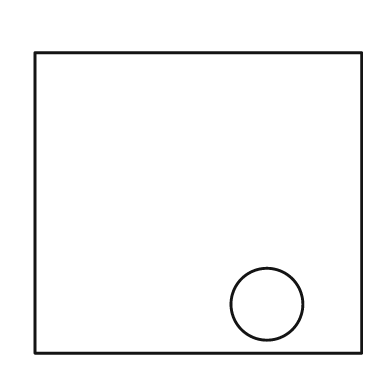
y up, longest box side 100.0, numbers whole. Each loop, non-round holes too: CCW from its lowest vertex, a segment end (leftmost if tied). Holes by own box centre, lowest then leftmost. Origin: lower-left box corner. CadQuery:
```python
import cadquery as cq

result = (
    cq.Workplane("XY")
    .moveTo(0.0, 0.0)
    .lineTo(100.0, 0.0)
    .lineTo(100.0, 92.0)
    .lineTo(0.0, 92.0)
    .close()
    .moveTo(71.0, 15.0)
    .circle(11.0)
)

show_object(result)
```